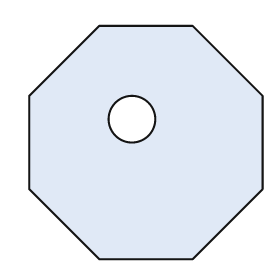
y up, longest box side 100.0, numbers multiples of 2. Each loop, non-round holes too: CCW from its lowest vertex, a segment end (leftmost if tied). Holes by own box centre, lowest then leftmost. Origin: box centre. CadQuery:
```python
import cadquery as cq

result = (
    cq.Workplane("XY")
    .moveTo(-20.0, -50.0)
    .lineTo(20.0, -50.0)
    .lineTo(50.0, -20.0)
    .lineTo(50.0, 20.0)
    .lineTo(20.0, 50.0)
    .lineTo(-20.0, 50.0)
    .lineTo(-50.0, 20.0)
    .lineTo(-50.0, -20.0)
    .close()
    .moveTo(-6.0, 10.0)
    .circle(10.0)
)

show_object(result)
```